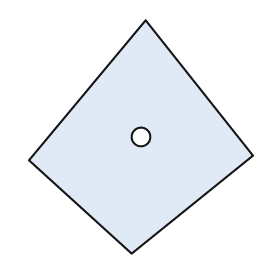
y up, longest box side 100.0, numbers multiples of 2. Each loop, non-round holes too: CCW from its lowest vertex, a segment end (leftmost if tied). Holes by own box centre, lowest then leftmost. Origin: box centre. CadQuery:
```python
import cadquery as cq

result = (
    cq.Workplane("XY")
    .moveTo(-4.0, -50.0)
    .lineTo(48.0, -8.0)
    .lineTo(2.0, 50.0)
    .lineTo(-48.0, -10.0)
    .close()
    .moveTo(0.0, 0.0)
    .circle(4.0)
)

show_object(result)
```